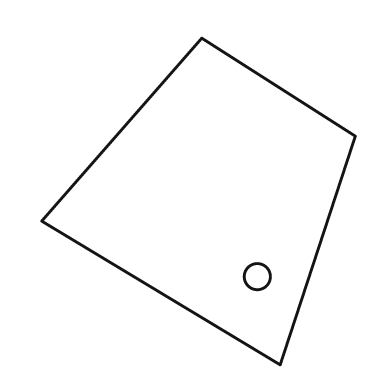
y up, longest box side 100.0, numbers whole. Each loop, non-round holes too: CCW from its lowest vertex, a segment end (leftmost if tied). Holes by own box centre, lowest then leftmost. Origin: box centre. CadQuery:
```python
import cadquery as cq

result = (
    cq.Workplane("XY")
    .moveTo(25.0, -50.0)
    .lineTo(48.0, 20.0)
    .lineTo(1.0, 50.0)
    .lineTo(-48.0, -6.0)
    .close()
    .moveTo(18.0, -23.0)
    .circle(4.0)
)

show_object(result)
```